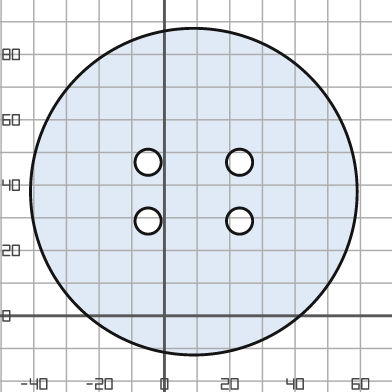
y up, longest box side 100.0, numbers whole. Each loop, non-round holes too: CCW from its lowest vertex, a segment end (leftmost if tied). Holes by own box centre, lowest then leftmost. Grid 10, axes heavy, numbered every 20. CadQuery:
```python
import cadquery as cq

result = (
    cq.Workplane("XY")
    .moveTo(9.0, 38.0)
    .circle(50.0)
    .moveTo(-5.0, 29.0)
    .circle(4.0)
    .moveTo(23.0, 29.0)
    .circle(4.0)
    .moveTo(-5.0, 47.0)
    .circle(4.0)
    .moveTo(23.0, 47.0)
    .circle(4.0)
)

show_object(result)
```